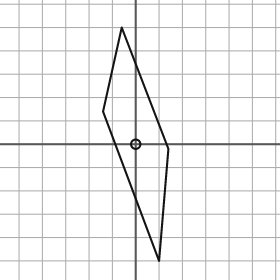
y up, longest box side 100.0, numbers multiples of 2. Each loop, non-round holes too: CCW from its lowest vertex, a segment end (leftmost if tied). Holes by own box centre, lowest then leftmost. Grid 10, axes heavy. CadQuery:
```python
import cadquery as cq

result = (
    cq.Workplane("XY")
    .moveTo(10.0, -50.0)
    .lineTo(14.0, -2.0)
    .lineTo(-6.0, 50.0)
    .lineTo(-14.0, 14.0)
    .close()
    .moveTo(0.0, 0.0)
    .circle(2.0)
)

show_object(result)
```